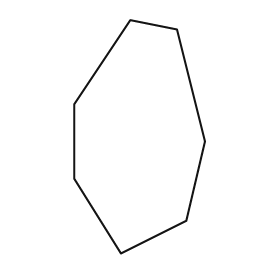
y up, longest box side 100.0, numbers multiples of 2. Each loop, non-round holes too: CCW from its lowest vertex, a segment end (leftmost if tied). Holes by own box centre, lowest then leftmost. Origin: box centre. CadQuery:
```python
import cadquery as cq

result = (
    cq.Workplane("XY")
    .moveTo(-8.0, -50.0)
    .lineTo(20.0, -36.0)
    .lineTo(28.0, -2.0)
    .lineTo(16.0, 46.0)
    .lineTo(-4.0, 50.0)
    .lineTo(-28.0, 14.0)
    .lineTo(-28.0, -18.0)
    .close()
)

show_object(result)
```